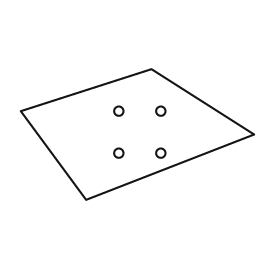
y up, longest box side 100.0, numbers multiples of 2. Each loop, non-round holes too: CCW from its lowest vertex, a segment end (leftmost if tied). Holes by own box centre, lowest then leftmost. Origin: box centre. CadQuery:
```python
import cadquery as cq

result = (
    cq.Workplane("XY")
    .moveTo(-22.0, -28.0)
    .lineTo(50.0, 0.0)
    .lineTo(6.0, 28.0)
    .lineTo(-50.0, 10.0)
    .close()
    .moveTo(-8.0, -8.0)
    .circle(2.0)
    .moveTo(10.0, -8.0)
    .circle(2.0)
    .moveTo(-8.0, 10.0)
    .circle(2.0)
    .moveTo(10.0, 10.0)
    .circle(2.0)
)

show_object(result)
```